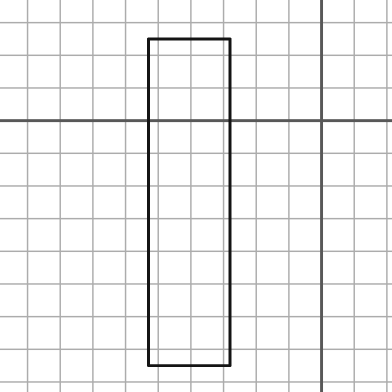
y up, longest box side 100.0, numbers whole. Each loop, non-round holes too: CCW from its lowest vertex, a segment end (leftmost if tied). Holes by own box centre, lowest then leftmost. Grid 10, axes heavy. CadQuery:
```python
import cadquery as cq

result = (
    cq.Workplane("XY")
    .moveTo(-53.0, -75.0)
    .lineTo(-28.0, -75.0)
    .lineTo(-28.0, 25.0)
    .lineTo(-53.0, 25.0)
    .close()
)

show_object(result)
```